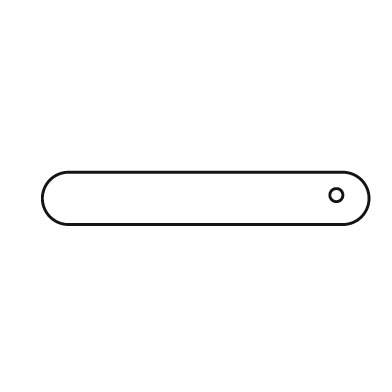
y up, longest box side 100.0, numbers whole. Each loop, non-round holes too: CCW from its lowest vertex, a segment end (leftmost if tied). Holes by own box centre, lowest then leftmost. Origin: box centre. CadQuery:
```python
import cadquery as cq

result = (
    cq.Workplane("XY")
    .moveTo(-42.0, -8.0)
    .lineTo(42.0, -8.0)
    .threePointArc((50.0, 0.0), (42.0, 8.0))
    .lineTo(-42.0, 8.0)
    .threePointArc((-50.0, 0.0), (-42.0, -8.0))
    .close()
    .moveTo(40.0, 1.0)
    .circle(2.0)
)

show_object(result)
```